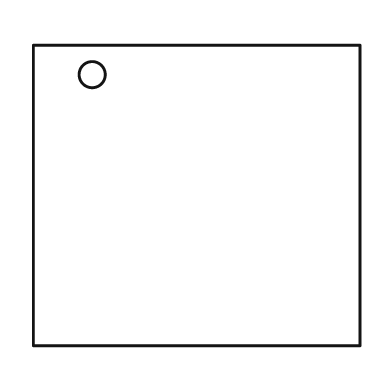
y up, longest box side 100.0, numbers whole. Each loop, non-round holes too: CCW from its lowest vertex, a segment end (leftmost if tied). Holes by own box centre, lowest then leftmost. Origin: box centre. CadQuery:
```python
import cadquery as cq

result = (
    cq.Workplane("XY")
    .moveTo(-50.0, -46.0)
    .lineTo(50.0, -46.0)
    .lineTo(50.0, 46.0)
    .lineTo(-50.0, 46.0)
    .close()
    .moveTo(-32.0, 37.0)
    .circle(4.0)
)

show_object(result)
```